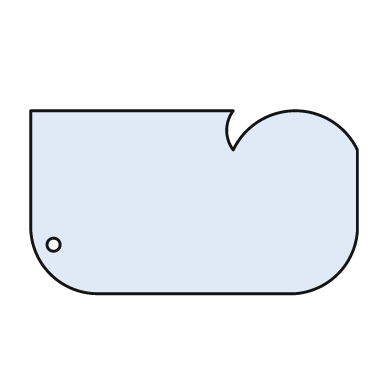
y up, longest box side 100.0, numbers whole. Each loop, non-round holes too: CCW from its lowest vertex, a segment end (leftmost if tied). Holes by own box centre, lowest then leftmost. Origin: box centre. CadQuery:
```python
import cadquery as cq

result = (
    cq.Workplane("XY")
    .moveTo(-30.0, -28.0)
    .lineTo(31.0, -28.0)
    .threePointArc((44.0, -22.0), (50.0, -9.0))
    .lineTo(50.0, 16.0)
    .threePointArc((31.0, 28.0), (12.0, 16.0))
    .threePointArc((10.0, 22.0), (12.0, 28.0))
    .lineTo(-50.0, 28.0)
    .lineTo(-50.0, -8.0)
    .threePointArc((-44.0, -22.0), (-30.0, -28.0))
    .close()
    .moveTo(-43.0, -13.0)
    .circle(2.0)
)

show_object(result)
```